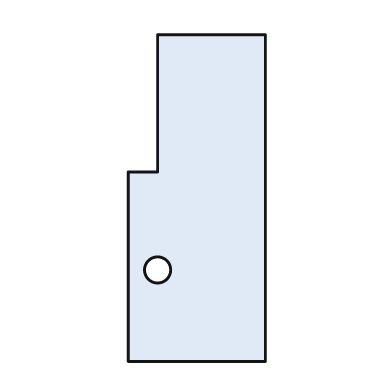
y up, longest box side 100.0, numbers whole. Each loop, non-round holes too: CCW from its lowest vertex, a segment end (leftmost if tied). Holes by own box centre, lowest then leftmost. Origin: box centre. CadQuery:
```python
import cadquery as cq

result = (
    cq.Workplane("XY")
    .moveTo(-21.0, -50.0)
    .lineTo(21.0, -50.0)
    .lineTo(21.0, 50.0)
    .lineTo(-12.0, 50.0)
    .lineTo(-12.0, 8.0)
    .lineTo(-21.0, 8.0)
    .close()
    .moveTo(-12.0, -22.0)
    .circle(4.0)
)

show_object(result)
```